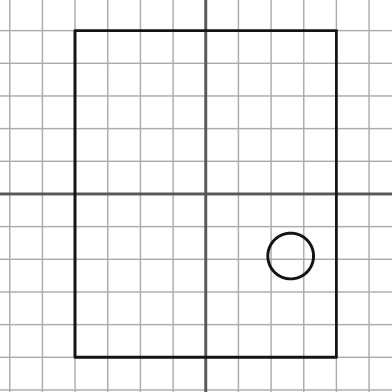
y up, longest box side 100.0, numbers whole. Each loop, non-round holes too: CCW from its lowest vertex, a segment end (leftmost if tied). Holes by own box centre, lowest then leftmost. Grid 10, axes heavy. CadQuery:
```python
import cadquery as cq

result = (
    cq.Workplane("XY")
    .moveTo(-40.0, -50.0)
    .lineTo(40.0, -50.0)
    .lineTo(40.0, 50.0)
    .lineTo(-40.0, 50.0)
    .close()
    .moveTo(26.0, -19.0)
    .circle(7.0)
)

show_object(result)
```